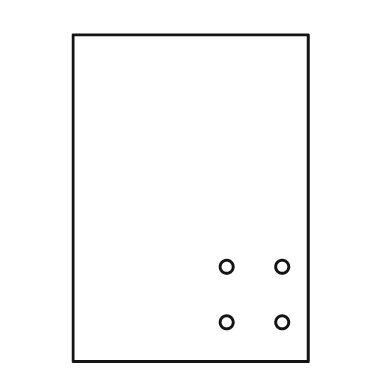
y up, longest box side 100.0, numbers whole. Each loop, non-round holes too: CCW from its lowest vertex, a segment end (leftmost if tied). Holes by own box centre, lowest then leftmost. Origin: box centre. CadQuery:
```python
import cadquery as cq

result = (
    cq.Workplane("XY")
    .moveTo(-36.0, -50.0)
    .lineTo(36.0, -50.0)
    .lineTo(36.0, 50.0)
    .lineTo(-36.0, 50.0)
    .close()
    .moveTo(11.0, -38.0)
    .circle(2.0)
    .moveTo(28.0, -38.0)
    .circle(2.0)
    .moveTo(11.0, -21.0)
    .circle(2.0)
    .moveTo(28.0, -21.0)
    .circle(2.0)
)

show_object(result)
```